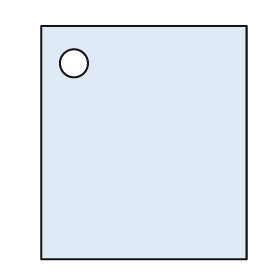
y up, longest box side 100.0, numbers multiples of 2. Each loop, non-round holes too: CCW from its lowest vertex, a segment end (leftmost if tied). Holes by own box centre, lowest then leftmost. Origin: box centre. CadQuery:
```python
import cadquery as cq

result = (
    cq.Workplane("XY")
    .moveTo(-44.0, -50.0)
    .lineTo(44.0, -50.0)
    .lineTo(44.0, 50.0)
    .lineTo(-44.0, 50.0)
    .close()
    .moveTo(-30.0, 34.0)
    .circle(6.0)
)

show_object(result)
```